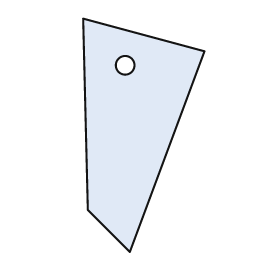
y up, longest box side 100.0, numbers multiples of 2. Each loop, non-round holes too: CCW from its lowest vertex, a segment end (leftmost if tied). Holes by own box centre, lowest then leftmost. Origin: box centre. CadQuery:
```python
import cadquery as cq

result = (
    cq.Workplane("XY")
    .moveTo(-6.0, -50.0)
    .lineTo(26.0, 36.0)
    .lineTo(-26.0, 50.0)
    .lineTo(-24.0, -32.0)
    .close()
    .moveTo(-8.0, 30.0)
    .circle(4.0)
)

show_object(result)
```